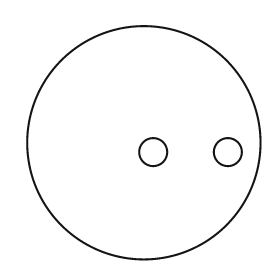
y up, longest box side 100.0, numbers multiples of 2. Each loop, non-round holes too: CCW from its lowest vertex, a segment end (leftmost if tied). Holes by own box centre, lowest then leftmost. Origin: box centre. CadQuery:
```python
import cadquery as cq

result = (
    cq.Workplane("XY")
    .moveTo(0.0, 0.0)
    .circle(50.0)
    .moveTo(4.0, -4.0)
    .circle(6.0)
    .moveTo(36.0, -4.0)
    .circle(6.0)
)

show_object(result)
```